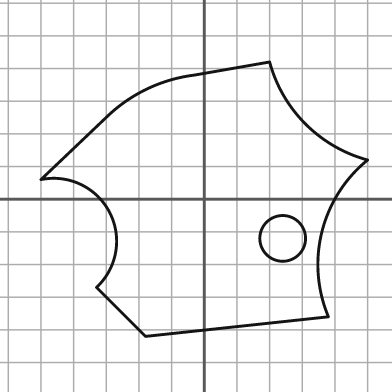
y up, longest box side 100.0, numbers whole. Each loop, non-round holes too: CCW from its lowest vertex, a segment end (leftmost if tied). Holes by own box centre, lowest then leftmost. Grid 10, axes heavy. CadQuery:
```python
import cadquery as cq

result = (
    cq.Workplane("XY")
    .moveTo(-18.0, -42.0)
    .lineTo(38.0, -36.0)
    .threePointArc((36.0, -10.0), (50.0, 12.0))
    .threePointArc((31.0, 23.0), (20.0, 42.0))
    .lineTo(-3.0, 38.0)
    .threePointArc((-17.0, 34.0), (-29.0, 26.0))
    .lineTo(-50.0, 6.0)
    .threePointArc((-29.0, -4.0), (-33.0, -27.0))
    .close()
    .moveTo(24.0, -12.0)
    .circle(7.0)
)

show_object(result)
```